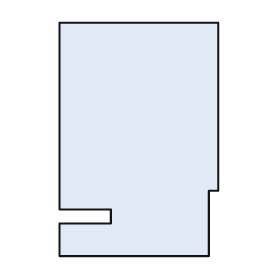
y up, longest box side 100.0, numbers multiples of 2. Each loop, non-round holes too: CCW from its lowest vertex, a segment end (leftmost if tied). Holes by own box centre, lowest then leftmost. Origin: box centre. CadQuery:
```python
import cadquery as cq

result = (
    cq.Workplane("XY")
    .moveTo(-34.0, -50.0)
    .lineTo(30.0, -50.0)
    .lineTo(30.0, -22.0)
    .lineTo(34.0, -22.0)
    .lineTo(34.0, 50.0)
    .lineTo(-34.0, 50.0)
    .lineTo(-34.0, -30.0)
    .lineTo(-12.0, -30.0)
    .lineTo(-12.0, -36.0)
    .lineTo(-34.0, -36.0)
    .close()
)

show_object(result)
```